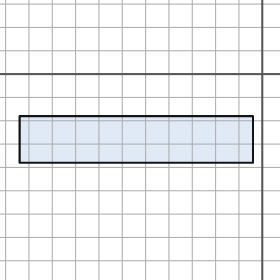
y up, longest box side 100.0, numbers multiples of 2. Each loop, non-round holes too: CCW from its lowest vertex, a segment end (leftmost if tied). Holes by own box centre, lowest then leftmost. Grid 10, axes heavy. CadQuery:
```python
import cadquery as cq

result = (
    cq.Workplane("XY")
    .moveTo(-104.0, -38.0)
    .lineTo(-4.0, -38.0)
    .lineTo(-4.0, -18.0)
    .lineTo(-104.0, -18.0)
    .close()
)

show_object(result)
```